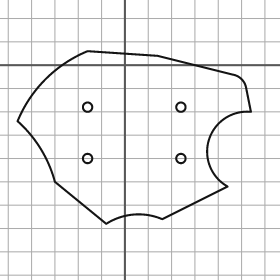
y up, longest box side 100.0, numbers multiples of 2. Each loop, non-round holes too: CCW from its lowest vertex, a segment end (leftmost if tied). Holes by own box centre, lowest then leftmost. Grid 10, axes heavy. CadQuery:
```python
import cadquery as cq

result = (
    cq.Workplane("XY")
    .moveTo(-8.0, -68.0)
    .threePointArc((4.0, -64.0), (16.0, -66.0))
    .lineTo(44.0, -52.0)
    .threePointArc((36.0, -32.0), (54.0, -20.0))
    .lineTo(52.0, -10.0)
    .threePointArc((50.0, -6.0), (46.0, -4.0))
    .lineTo(14.0, 4.0)
    .lineTo(-16.0, 6.0)
    .threePointArc((-34.0, -6.0), (-46.0, -24.0))
    .threePointArc((-36.0, -36.0), (-30.0, -50.0))
    .close()
    .moveTo(-16.0, -40.0)
    .circle(2.0)
    .moveTo(24.0, -40.0)
    .circle(2.0)
    .moveTo(-16.0, -18.0)
    .circle(2.0)
    .moveTo(24.0, -18.0)
    .circle(2.0)
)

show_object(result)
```